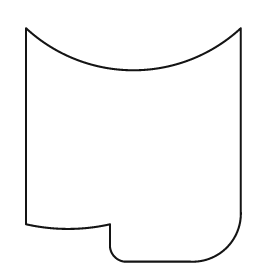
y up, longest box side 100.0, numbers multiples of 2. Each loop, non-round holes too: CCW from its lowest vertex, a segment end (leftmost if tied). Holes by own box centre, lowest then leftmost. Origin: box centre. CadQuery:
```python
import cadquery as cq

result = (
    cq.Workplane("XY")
    .moveTo(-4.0, -50.0)
    .lineTo(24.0, -50.0)
    .threePointArc((40.0, -44.0), (46.0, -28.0))
    .lineTo(46.0, 50.0)
    .threePointArc((0.0, 32.0), (-46.0, 50.0))
    .lineTo(-46.0, -34.0)
    .threePointArc((-28.0, -36.0), (-10.0, -34.0))
    .lineTo(-10.0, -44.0)
    .threePointArc((-8.0, -48.0), (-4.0, -50.0))
    .close()
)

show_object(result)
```